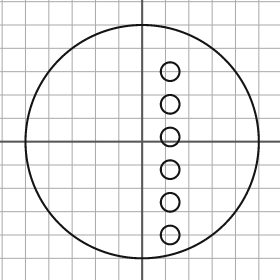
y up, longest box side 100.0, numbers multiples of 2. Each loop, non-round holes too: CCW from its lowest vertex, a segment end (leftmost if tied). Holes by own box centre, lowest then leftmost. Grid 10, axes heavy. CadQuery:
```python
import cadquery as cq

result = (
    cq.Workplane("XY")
    .moveTo(0.0, 0.0)
    .circle(50.0)
    .moveTo(12.0, -40.0)
    .circle(4.0)
    .moveTo(12.0, -26.0)
    .circle(4.0)
    .moveTo(12.0, -12.0)
    .circle(4.0)
    .moveTo(12.0, 2.0)
    .circle(4.0)
    .moveTo(12.0, 16.0)
    .circle(4.0)
    .moveTo(12.0, 30.0)
    .circle(4.0)
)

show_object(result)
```